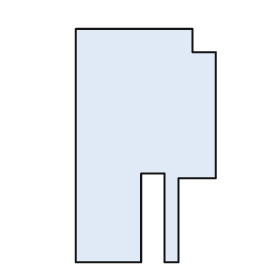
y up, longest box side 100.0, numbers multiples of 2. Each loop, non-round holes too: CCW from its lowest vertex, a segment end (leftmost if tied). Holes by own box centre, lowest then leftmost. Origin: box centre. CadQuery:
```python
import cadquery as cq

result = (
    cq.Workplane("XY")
    .moveTo(-30.0, -50.0)
    .lineTo(-2.0, -50.0)
    .lineTo(-2.0, -12.0)
    .lineTo(8.0, -12.0)
    .lineTo(8.0, -50.0)
    .lineTo(14.0, -50.0)
    .lineTo(14.0, -14.0)
    .lineTo(30.0, -14.0)
    .lineTo(30.0, 40.0)
    .lineTo(20.0, 40.0)
    .lineTo(20.0, 50.0)
    .lineTo(-30.0, 50.0)
    .close()
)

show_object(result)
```